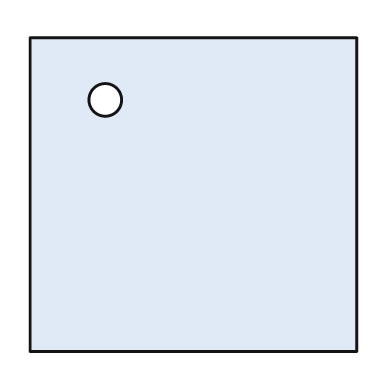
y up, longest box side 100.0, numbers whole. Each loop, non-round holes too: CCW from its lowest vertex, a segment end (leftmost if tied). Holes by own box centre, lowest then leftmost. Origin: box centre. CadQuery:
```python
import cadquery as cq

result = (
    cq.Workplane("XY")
    .moveTo(-50.0, -48.0)
    .lineTo(50.0, -48.0)
    .lineTo(50.0, 48.0)
    .lineTo(-50.0, 48.0)
    .close()
    .moveTo(-27.0, 29.0)
    .circle(5.0)
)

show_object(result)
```